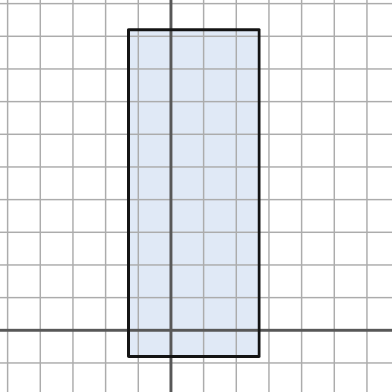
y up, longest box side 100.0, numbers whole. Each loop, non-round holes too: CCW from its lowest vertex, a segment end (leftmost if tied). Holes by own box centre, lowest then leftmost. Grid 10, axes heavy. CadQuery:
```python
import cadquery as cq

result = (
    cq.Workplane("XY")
    .moveTo(-13.0, -8.0)
    .lineTo(27.0, -8.0)
    .lineTo(27.0, 92.0)
    .lineTo(-13.0, 92.0)
    .close()
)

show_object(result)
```